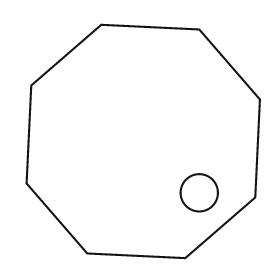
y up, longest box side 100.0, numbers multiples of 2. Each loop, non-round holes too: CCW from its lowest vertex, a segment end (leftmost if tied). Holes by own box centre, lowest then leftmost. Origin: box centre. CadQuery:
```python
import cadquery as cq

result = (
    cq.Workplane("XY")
    .moveTo(18.0, -50.0)
    .lineTo(48.0, -24.0)
    .lineTo(50.0, 18.0)
    .lineTo(24.0, 48.0)
    .lineTo(-18.0, 50.0)
    .lineTo(-48.0, 24.0)
    .lineTo(-50.0, -18.0)
    .lineTo(-24.0, -48.0)
    .close()
    .moveTo(24.0, -22.0)
    .circle(8.0)
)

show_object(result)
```